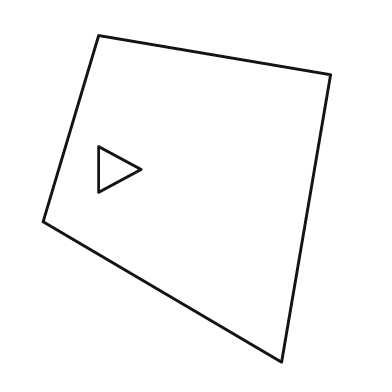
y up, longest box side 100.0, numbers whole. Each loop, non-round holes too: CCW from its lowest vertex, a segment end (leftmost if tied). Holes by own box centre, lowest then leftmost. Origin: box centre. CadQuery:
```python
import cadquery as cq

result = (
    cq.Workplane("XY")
    .moveTo(29.0, -50.0)
    .lineTo(44.0, 38.0)
    .lineTo(-27.0, 50.0)
    .lineTo(-44.0, -7.0)
    .close()
    .moveTo(-27.0, 2.0)
    .lineTo(-14.0, 9.0)
    .lineTo(-27.0, 16.0)
    .close()
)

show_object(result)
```